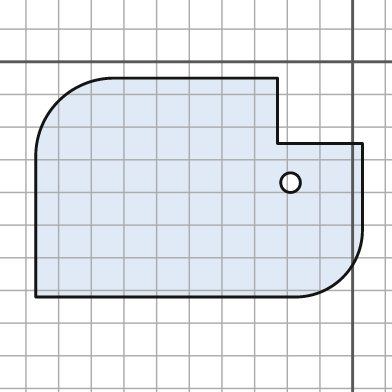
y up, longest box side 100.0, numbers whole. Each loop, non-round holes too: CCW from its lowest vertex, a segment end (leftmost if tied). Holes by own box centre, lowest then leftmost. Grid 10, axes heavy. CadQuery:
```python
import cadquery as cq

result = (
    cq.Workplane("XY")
    .moveTo(-97.0, -72.0)
    .lineTo(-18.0, -72.0)
    .threePointArc((-3.0, -66.0), (3.0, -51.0))
    .lineTo(3.0, -25.0)
    .lineTo(-23.0, -25.0)
    .lineTo(-23.0, -5.0)
    .lineTo(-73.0, -5.0)
    .threePointArc((-90.0, -12.0), (-97.0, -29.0))
    .close()
    .moveTo(-19.0, -37.0)
    .circle(3.0)
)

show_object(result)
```